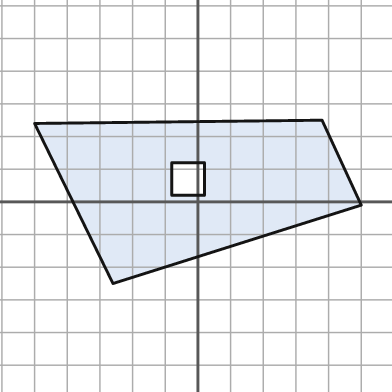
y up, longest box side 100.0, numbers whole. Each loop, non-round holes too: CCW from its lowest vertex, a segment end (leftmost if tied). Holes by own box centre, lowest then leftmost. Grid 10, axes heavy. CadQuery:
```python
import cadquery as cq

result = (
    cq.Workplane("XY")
    .moveTo(-26.0, -25.0)
    .lineTo(50.0, -1.0)
    .lineTo(38.0, 25.0)
    .lineTo(-50.0, 24.0)
    .close()
    .moveTo(-8.0, 2.0)
    .lineTo(2.0, 2.0)
    .lineTo(2.0, 12.0)
    .lineTo(-8.0, 12.0)
    .close()
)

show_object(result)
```